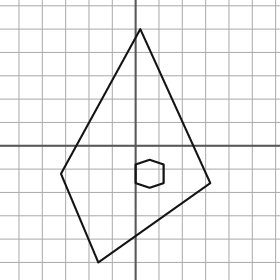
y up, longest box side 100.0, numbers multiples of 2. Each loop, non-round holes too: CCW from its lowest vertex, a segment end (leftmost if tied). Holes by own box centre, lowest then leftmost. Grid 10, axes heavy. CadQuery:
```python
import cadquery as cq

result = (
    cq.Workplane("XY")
    .moveTo(-16.0, -50.0)
    .lineTo(32.0, -16.0)
    .lineTo(2.0, 50.0)
    .lineTo(-32.0, -12.0)
    .close()
    .moveTo(6.0, -18.0)
    .lineTo(12.0, -16.0)
    .lineTo(12.0, -8.0)
    .lineTo(6.0, -6.0)
    .lineTo(0.0, -8.0)
    .lineTo(0.0, -16.0)
    .close()
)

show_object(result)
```